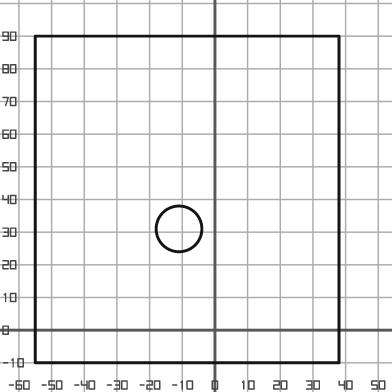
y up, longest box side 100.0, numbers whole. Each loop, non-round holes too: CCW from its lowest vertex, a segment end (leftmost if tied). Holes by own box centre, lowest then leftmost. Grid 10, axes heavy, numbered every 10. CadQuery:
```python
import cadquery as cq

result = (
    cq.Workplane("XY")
    .moveTo(-55.0, -10.0)
    .lineTo(38.0, -10.0)
    .lineTo(38.0, 90.0)
    .lineTo(-55.0, 90.0)
    .close()
    .moveTo(-11.0, 31.0)
    .circle(7.0)
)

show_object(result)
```